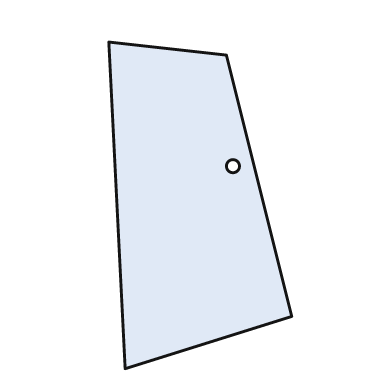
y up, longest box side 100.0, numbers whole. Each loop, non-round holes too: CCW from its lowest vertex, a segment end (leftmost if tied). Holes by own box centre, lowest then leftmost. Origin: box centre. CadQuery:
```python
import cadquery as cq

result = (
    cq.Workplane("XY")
    .moveTo(-23.0, -50.0)
    .lineTo(28.0, -34.0)
    .lineTo(8.0, 46.0)
    .lineTo(-28.0, 50.0)
    .close()
    .moveTo(10.0, 12.0)
    .circle(2.0)
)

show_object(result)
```